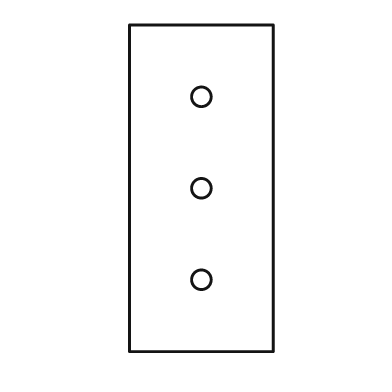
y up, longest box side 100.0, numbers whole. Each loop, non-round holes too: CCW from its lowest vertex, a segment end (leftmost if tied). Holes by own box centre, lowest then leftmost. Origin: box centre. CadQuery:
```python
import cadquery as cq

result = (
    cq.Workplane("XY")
    .moveTo(-22.0, -50.0)
    .lineTo(22.0, -50.0)
    .lineTo(22.0, 50.0)
    .lineTo(-22.0, 50.0)
    .close()
    .moveTo(0.0, -28.0)
    .circle(3.0)
    .moveTo(0.0, 0.0)
    .circle(3.0)
    .moveTo(0.0, 28.0)
    .circle(3.0)
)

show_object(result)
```